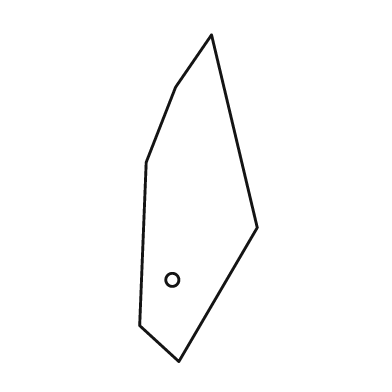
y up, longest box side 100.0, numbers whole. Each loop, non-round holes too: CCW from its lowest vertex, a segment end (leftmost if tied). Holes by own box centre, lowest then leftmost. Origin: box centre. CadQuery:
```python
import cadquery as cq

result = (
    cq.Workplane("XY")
    .moveTo(-6.0, -50.0)
    .lineTo(18.0, -9.0)
    .lineTo(4.0, 50.0)
    .lineTo(-7.0, 34.0)
    .lineTo(-16.0, 11.0)
    .lineTo(-18.0, -39.0)
    .close()
    .moveTo(-8.0, -25.0)
    .circle(2.0)
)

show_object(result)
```